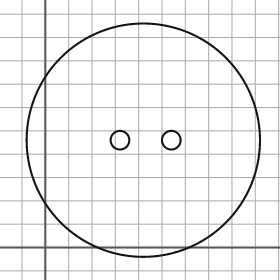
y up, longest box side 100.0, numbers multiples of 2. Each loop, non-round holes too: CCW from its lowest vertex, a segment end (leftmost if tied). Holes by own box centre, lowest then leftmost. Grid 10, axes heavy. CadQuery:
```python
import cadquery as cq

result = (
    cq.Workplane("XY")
    .moveTo(42.0, 46.0)
    .circle(50.0)
    .moveTo(32.0, 46.0)
    .circle(4.0)
    .moveTo(54.0, 46.0)
    .circle(4.0)
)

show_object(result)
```